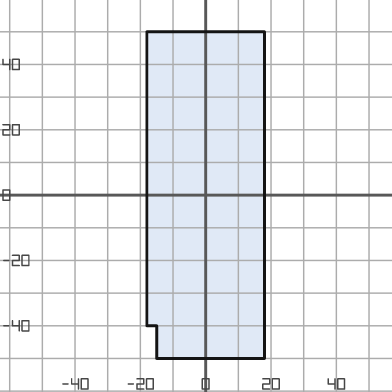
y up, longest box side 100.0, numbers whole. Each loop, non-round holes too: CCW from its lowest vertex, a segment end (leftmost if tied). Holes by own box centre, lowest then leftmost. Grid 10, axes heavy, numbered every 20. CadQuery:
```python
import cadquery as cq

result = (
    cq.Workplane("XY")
    .moveTo(-15.0, -50.0)
    .lineTo(18.0, -50.0)
    .lineTo(18.0, 50.0)
    .lineTo(-18.0, 50.0)
    .lineTo(-18.0, -40.0)
    .lineTo(-15.0, -40.0)
    .close()
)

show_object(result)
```